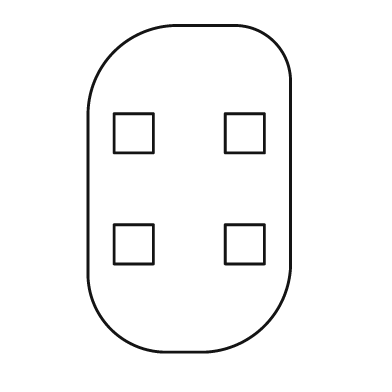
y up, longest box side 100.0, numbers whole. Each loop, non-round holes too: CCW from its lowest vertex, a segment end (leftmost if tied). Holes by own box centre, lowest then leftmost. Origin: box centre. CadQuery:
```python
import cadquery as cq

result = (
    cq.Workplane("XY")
    .moveTo(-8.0, -50.0)
    .lineTo(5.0, -50.0)
    .threePointArc((23.0, -42.0), (31.0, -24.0))
    .lineTo(31.0, 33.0)
    .threePointArc((26.0, 45.0), (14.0, 50.0))
    .lineTo(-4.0, 50.0)
    .threePointArc((-23.0, 42.0), (-31.0, 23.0))
    .lineTo(-31.0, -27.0)
    .threePointArc((-24.0, -43.0), (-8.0, -50.0))
    .close()
    .moveTo(-23.0, -23.0)
    .lineTo(-11.0, -23.0)
    .lineTo(-11.0, -11.0)
    .lineTo(-23.0, -11.0)
    .close()
    .moveTo(11.0, -23.0)
    .lineTo(23.0, -23.0)
    .lineTo(23.0, -11.0)
    .lineTo(11.0, -11.0)
    .close()
    .moveTo(-23.0, 11.0)
    .lineTo(-11.0, 11.0)
    .lineTo(-11.0, 23.0)
    .lineTo(-23.0, 23.0)
    .close()
    .moveTo(11.0, 11.0)
    .lineTo(23.0, 11.0)
    .lineTo(23.0, 23.0)
    .lineTo(11.0, 23.0)
    .close()
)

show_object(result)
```